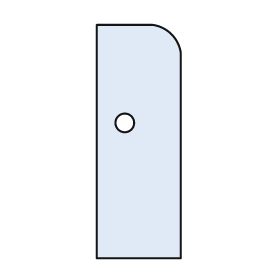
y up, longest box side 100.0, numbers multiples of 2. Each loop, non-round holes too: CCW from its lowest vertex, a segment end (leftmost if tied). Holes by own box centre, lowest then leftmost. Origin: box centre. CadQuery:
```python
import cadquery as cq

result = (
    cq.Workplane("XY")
    .moveTo(-18.0, -50.0)
    .lineTo(18.0, -50.0)
    .lineTo(18.0, 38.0)
    .threePointArc((14.0, 46.0), (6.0, 50.0))
    .lineTo(-18.0, 50.0)
    .close()
    .moveTo(-6.0, 8.0)
    .circle(4.0)
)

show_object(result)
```